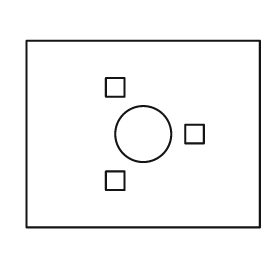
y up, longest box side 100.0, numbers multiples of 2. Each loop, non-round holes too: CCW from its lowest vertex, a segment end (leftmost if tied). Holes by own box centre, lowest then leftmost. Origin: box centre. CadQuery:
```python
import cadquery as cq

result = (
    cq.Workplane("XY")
    .moveTo(-50.0, -40.0)
    .lineTo(50.0, -40.0)
    .lineTo(50.0, 40.0)
    .lineTo(-50.0, 40.0)
    .close()
    .moveTo(-16.0, -24.0)
    .lineTo(-8.0, -24.0)
    .lineTo(-8.0, -16.0)
    .lineTo(-16.0, -16.0)
    .close()
    .moveTo(0.0, 0.0)
    .circle(12.0)
    .moveTo(18.0, -4.0)
    .lineTo(26.0, -4.0)
    .lineTo(26.0, 4.0)
    .lineTo(18.0, 4.0)
    .close()
    .moveTo(-16.0, 16.0)
    .lineTo(-8.0, 16.0)
    .lineTo(-8.0, 24.0)
    .lineTo(-16.0, 24.0)
    .close()
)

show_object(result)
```